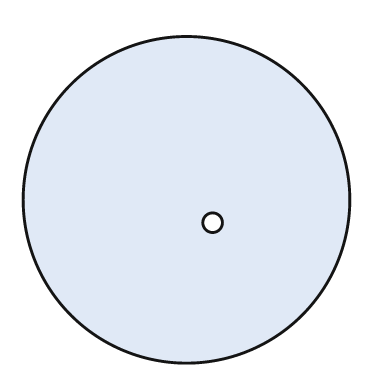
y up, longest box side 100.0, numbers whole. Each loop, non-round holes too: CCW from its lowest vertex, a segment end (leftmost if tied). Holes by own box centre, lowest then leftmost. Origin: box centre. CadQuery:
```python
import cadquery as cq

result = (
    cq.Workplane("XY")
    .moveTo(0.0, 0.0)
    .circle(50.0)
    .moveTo(8.0, -7.0)
    .circle(3.0)
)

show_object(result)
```